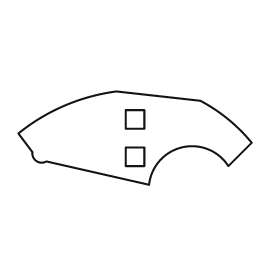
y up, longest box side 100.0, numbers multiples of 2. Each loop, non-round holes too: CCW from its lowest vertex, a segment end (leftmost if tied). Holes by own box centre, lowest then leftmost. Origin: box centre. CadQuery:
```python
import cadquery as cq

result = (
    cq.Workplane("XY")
    .moveTo(6.0, -20.0)
    .threePointArc((20.0, -4.0), (40.0, -12.0))
    .lineTo(50.0, -2.0)
    .threePointArc((40.0, 8.0), (28.0, 16.0))
    .lineTo(-8.0, 20.0)
    .threePointArc((-30.0, 14.0), (-50.0, 2.0))
    .lineTo(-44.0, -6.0)
    .threePointArc((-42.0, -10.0), (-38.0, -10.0))
    .close()
    .moveTo(-4.0, -12.0)
    .lineTo(4.0, -12.0)
    .lineTo(4.0, -4.0)
    .lineTo(-4.0, -4.0)
    .close()
    .moveTo(-4.0, 4.0)
    .lineTo(4.0, 4.0)
    .lineTo(4.0, 12.0)
    .lineTo(-4.0, 12.0)
    .close()
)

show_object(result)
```